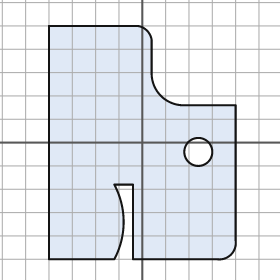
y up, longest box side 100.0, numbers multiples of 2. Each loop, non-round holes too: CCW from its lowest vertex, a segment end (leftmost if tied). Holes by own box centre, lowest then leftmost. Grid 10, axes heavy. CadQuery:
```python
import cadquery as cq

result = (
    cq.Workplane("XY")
    .moveTo(-40.0, -50.0)
    .lineTo(-12.0, -50.0)
    .threePointArc((-8.0, -34.0), (-12.0, -18.0))
    .lineTo(-4.0, -18.0)
    .lineTo(-4.0, -50.0)
    .lineTo(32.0, -50.0)
    .threePointArc((38.0, -48.0), (40.0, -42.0))
    .lineTo(40.0, 16.0)
    .lineTo(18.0, 16.0)
    .threePointArc((8.0, 20.0), (4.0, 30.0))
    .lineTo(4.0, 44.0)
    .threePointArc((2.0, 48.0), (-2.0, 50.0))
    .lineTo(-40.0, 50.0)
    .close()
    .moveTo(24.0, -4.0)
    .circle(6.0)
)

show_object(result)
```